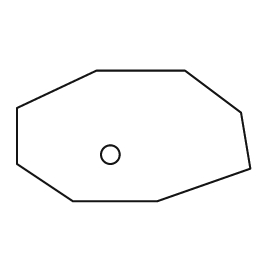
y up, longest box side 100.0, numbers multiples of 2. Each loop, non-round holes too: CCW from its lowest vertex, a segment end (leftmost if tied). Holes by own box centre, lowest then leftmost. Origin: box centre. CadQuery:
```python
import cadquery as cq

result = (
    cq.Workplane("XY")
    .moveTo(-26.0, -28.0)
    .lineTo(10.0, -28.0)
    .lineTo(50.0, -14.0)
    .lineTo(46.0, 10.0)
    .lineTo(22.0, 28.0)
    .lineTo(-16.0, 28.0)
    .lineTo(-50.0, 12.0)
    .lineTo(-50.0, -12.0)
    .close()
    .moveTo(-10.0, -8.0)
    .circle(4.0)
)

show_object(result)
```